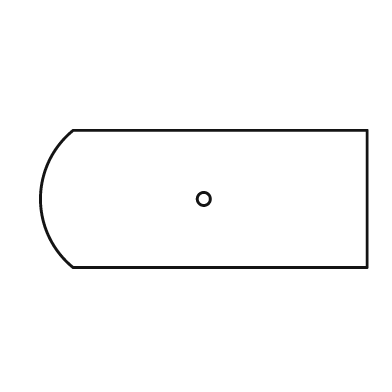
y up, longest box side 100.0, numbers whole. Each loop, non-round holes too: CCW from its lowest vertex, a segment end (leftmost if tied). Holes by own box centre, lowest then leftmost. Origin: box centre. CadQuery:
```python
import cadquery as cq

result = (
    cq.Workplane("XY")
    .moveTo(-40.0, -21.0)
    .lineTo(50.0, -21.0)
    .lineTo(50.0, 21.0)
    .lineTo(-40.0, 21.0)
    .threePointArc((-50.0, 0.0), (-40.0, -21.0))
    .close()
    .moveTo(0.0, 0.0)
    .circle(2.0)
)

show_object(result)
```